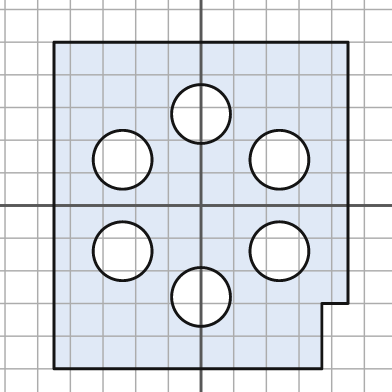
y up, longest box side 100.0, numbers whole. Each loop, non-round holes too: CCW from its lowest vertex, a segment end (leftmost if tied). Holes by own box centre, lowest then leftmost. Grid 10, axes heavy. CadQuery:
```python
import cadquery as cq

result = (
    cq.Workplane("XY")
    .moveTo(-45.0, -50.0)
    .lineTo(37.0, -50.0)
    .lineTo(37.0, -30.0)
    .lineTo(45.0, -30.0)
    .lineTo(45.0, 50.0)
    .lineTo(-45.0, 50.0)
    .close()
    .moveTo(0.0, -28.0)
    .circle(9.0)
    .moveTo(-24.0, -14.0)
    .circle(9.0)
    .moveTo(24.0, -14.0)
    .circle(9.0)
    .moveTo(-24.0, 14.0)
    .circle(9.0)
    .moveTo(24.0, 14.0)
    .circle(9.0)
    .moveTo(0.0, 28.0)
    .circle(9.0)
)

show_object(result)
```